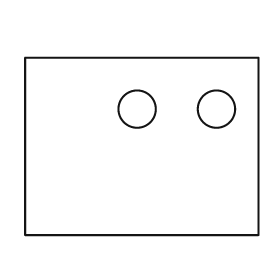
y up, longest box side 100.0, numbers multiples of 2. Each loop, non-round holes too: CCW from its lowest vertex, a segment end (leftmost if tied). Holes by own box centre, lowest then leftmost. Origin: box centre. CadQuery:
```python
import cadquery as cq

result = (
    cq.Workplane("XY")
    .moveTo(-50.0, -38.0)
    .lineTo(50.0, -38.0)
    .lineTo(50.0, 38.0)
    .lineTo(-50.0, 38.0)
    .close()
    .moveTo(-2.0, 16.0)
    .circle(8.0)
    .moveTo(32.0, 16.0)
    .circle(8.0)
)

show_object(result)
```